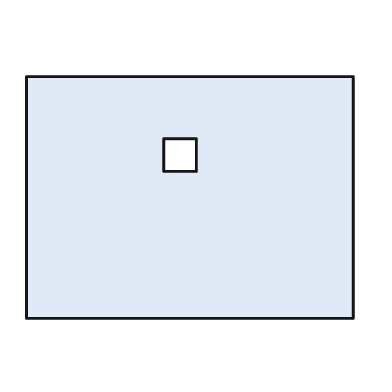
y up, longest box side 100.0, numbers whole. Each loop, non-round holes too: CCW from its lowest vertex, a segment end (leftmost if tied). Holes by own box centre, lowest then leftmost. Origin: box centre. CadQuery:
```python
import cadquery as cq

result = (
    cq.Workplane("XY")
    .moveTo(-50.0, -37.0)
    .lineTo(50.0, -37.0)
    .lineTo(50.0, 37.0)
    .lineTo(-50.0, 37.0)
    .close()
    .moveTo(-8.0, 8.0)
    .lineTo(2.0, 8.0)
    .lineTo(2.0, 18.0)
    .lineTo(-8.0, 18.0)
    .close()
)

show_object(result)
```